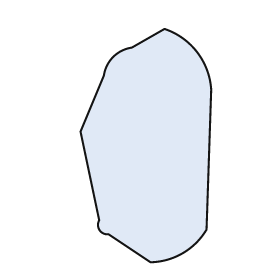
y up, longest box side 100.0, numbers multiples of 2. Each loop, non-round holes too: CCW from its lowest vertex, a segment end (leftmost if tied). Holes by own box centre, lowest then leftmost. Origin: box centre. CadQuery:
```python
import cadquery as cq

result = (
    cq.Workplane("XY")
    .moveTo(2.0, -50.0)
    .threePointArc((16.0, -46.0), (26.0, -36.0))
    .lineTo(28.0, 24.0)
    .threePointArc((22.0, 40.0), (8.0, 50.0))
    .lineTo(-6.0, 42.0)
    .threePointArc((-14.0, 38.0), (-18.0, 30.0))
    .lineTo(-28.0, 6.0)
    .lineTo(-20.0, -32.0)
    .threePointArc((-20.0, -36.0), (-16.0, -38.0))
    .close()
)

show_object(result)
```